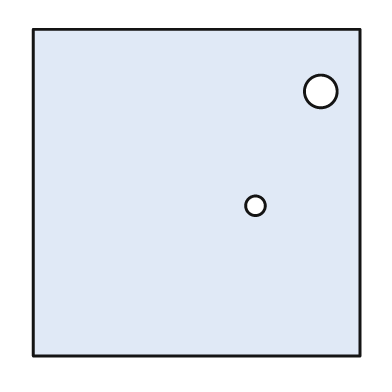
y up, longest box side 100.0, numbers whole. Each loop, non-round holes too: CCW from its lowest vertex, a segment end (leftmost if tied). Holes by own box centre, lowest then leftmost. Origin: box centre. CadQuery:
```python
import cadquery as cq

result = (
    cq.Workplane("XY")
    .moveTo(-50.0, -50.0)
    .lineTo(50.0, -50.0)
    .lineTo(50.0, 50.0)
    .lineTo(-50.0, 50.0)
    .close()
    .moveTo(18.0, -4.0)
    .circle(3.0)
    .moveTo(38.0, 31.0)
    .circle(5.0)
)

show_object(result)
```